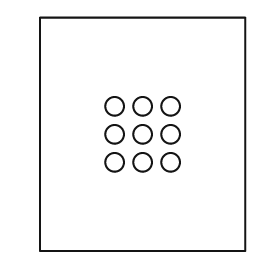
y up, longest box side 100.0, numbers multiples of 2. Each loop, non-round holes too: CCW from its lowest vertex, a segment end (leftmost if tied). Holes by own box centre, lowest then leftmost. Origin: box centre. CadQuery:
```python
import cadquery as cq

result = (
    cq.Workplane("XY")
    .moveTo(-44.0, -50.0)
    .lineTo(44.0, -50.0)
    .lineTo(44.0, 50.0)
    .lineTo(-44.0, 50.0)
    .close()
    .moveTo(-12.0, -12.0)
    .circle(4.0)
    .moveTo(0.0, -12.0)
    .circle(4.0)
    .moveTo(12.0, -12.0)
    .circle(4.0)
    .moveTo(-12.0, 0.0)
    .circle(4.0)
    .moveTo(0.0, 0.0)
    .circle(4.0)
    .moveTo(12.0, 0.0)
    .circle(4.0)
    .moveTo(-12.0, 12.0)
    .circle(4.0)
    .moveTo(0.0, 12.0)
    .circle(4.0)
    .moveTo(12.0, 12.0)
    .circle(4.0)
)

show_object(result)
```